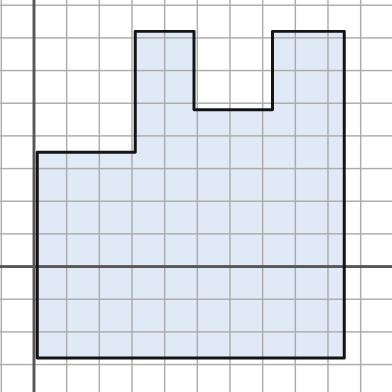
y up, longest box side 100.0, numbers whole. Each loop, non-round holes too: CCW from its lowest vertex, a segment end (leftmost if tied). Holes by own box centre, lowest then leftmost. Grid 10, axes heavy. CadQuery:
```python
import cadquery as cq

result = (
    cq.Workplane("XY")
    .moveTo(1.0, -28.0)
    .lineTo(95.0, -28.0)
    .lineTo(95.0, 72.0)
    .lineTo(73.0, 72.0)
    .lineTo(73.0, 48.0)
    .lineTo(49.0, 48.0)
    .lineTo(49.0, 72.0)
    .lineTo(31.0, 72.0)
    .lineTo(31.0, 35.0)
    .lineTo(1.0, 35.0)
    .close()
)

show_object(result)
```